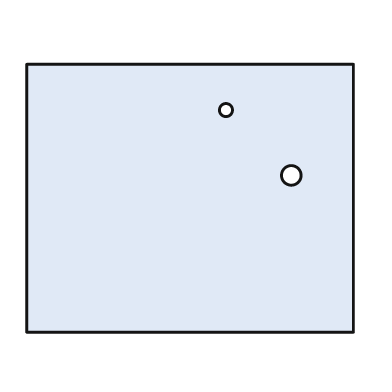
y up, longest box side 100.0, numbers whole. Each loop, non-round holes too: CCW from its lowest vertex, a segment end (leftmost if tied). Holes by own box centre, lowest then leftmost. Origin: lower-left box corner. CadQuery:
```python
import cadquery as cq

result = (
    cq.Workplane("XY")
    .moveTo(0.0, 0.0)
    .lineTo(100.0, 0.0)
    .lineTo(100.0, 82.0)
    .lineTo(0.0, 82.0)
    .close()
    .moveTo(81.0, 48.0)
    .circle(3.0)
    .moveTo(61.0, 68.0)
    .circle(2.0)
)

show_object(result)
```